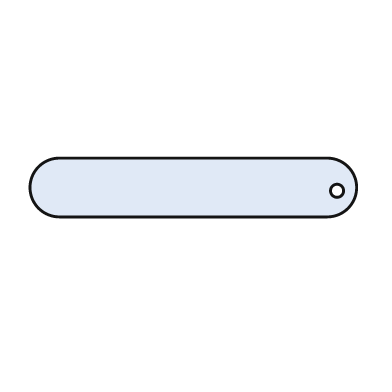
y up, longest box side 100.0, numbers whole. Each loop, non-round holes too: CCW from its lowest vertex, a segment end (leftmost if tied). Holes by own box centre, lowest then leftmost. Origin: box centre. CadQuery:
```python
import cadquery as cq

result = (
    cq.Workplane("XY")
    .moveTo(-41.0, -9.0)
    .lineTo(41.0, -9.0)
    .threePointArc((50.0, 0.0), (41.0, 9.0))
    .lineTo(-41.0, 9.0)
    .threePointArc((-50.0, 0.0), (-41.0, -9.0))
    .close()
    .moveTo(44.0, -1.0)
    .circle(2.0)
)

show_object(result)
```